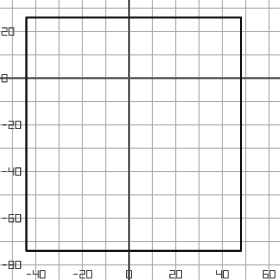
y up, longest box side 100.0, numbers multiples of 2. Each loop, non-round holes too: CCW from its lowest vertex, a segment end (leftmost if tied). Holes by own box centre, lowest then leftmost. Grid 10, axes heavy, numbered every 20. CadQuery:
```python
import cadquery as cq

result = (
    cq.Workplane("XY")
    .moveTo(-44.0, -74.0)
    .lineTo(48.0, -74.0)
    .lineTo(48.0, 26.0)
    .lineTo(-44.0, 26.0)
    .close()
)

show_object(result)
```